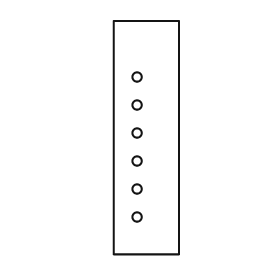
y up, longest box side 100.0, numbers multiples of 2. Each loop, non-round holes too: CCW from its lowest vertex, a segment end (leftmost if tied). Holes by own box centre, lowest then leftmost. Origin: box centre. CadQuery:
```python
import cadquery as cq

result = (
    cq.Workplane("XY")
    .moveTo(-14.0, -50.0)
    .lineTo(14.0, -50.0)
    .lineTo(14.0, 50.0)
    .lineTo(-14.0, 50.0)
    .close()
    .moveTo(-4.0, -34.0)
    .circle(2.0)
    .moveTo(-4.0, -22.0)
    .circle(2.0)
    .moveTo(-4.0, -10.0)
    .circle(2.0)
    .moveTo(-4.0, 2.0)
    .circle(2.0)
    .moveTo(-4.0, 14.0)
    .circle(2.0)
    .moveTo(-4.0, 26.0)
    .circle(2.0)
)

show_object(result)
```